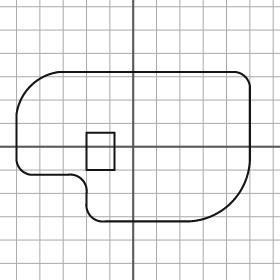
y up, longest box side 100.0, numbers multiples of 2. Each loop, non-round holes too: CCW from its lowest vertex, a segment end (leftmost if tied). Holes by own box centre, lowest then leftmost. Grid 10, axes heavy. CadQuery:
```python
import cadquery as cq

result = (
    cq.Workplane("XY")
    .moveTo(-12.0, -32.0)
    .lineTo(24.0, -32.0)
    .threePointArc((42.0, -24.0), (50.0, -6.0))
    .lineTo(50.0, 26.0)
    .threePointArc((48.0, 30.0), (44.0, 32.0))
    .lineTo(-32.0, 32.0)
    .threePointArc((-44.0, 26.0), (-50.0, 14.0))
    .lineTo(-50.0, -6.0)
    .threePointArc((-48.0, -10.0), (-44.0, -12.0))
    .lineTo(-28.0, -12.0)
    .threePointArc((-22.0, -14.0), (-20.0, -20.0))
    .lineTo(-20.0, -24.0)
    .threePointArc((-18.0, -30.0), (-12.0, -32.0))
    .close()
    .moveTo(-20.0, -10.0)
    .lineTo(-8.0, -10.0)
    .lineTo(-8.0, 6.0)
    .lineTo(-20.0, 6.0)
    .close()
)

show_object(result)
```